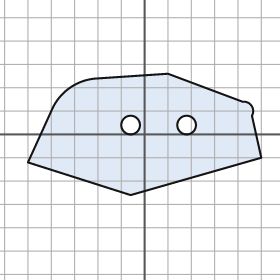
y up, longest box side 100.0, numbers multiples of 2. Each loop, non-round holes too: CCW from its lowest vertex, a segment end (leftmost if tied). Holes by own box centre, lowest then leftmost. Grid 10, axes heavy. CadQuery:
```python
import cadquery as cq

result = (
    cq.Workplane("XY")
    .moveTo(-6.0, -26.0)
    .lineTo(50.0, -10.0)
    .lineTo(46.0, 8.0)
    .threePointArc((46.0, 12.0), (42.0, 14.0))
    .lineTo(10.0, 26.0)
    .lineTo(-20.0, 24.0)
    .threePointArc((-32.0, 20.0), (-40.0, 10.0))
    .lineTo(-50.0, -12.0)
    .close()
    .moveTo(-6.0, 4.0)
    .circle(4.0)
    .moveTo(18.0, 4.0)
    .circle(4.0)
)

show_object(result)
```